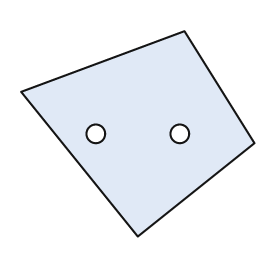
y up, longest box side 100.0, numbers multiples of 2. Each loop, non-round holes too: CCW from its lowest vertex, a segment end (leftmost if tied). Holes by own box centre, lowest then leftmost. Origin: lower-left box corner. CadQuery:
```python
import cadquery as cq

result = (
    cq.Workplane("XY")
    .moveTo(50.0, 0.0)
    .lineTo(100.0, 40.0)
    .lineTo(70.0, 88.0)
    .lineTo(0.0, 62.0)
    .close()
    .moveTo(32.0, 44.0)
    .circle(4.0)
    .moveTo(68.0, 44.0)
    .circle(4.0)
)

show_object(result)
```